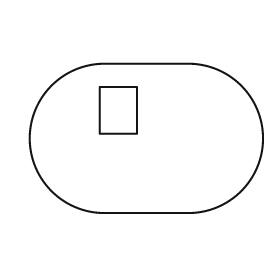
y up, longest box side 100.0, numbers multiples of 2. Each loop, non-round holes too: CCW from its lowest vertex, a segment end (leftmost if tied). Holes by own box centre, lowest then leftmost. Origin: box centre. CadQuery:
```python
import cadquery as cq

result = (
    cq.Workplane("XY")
    .moveTo(-18.0, -32.0)
    .lineTo(18.0, -32.0)
    .threePointArc((50.0, 0.0), (18.0, 32.0))
    .lineTo(-18.0, 32.0)
    .threePointArc((-50.0, 0.0), (-18.0, -32.0))
    .close()
    .moveTo(-20.0, 2.0)
    .lineTo(-4.0, 2.0)
    .lineTo(-4.0, 22.0)
    .lineTo(-20.0, 22.0)
    .close()
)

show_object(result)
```